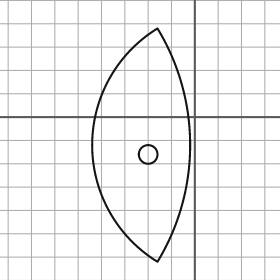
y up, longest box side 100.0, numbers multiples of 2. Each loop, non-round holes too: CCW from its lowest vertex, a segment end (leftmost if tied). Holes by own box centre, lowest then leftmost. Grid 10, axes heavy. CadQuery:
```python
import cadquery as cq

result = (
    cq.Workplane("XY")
    .moveTo(-16.0, -62.0)
    .threePointArc((-2.0, -12.0), (-16.0, 38.0))
    .threePointArc((-44.0, -12.0), (-16.0, -62.0))
    .close()
    .moveTo(-20.0, -16.0)
    .circle(4.0)
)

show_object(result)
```